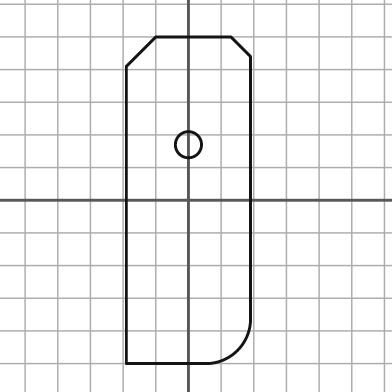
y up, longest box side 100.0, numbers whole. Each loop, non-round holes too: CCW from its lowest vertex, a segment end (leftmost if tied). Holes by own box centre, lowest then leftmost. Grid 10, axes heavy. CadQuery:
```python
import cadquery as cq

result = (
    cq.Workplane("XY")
    .moveTo(-19.0, -50.0)
    .lineTo(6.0, -50.0)
    .threePointArc((15.0, -46.0), (19.0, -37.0))
    .lineTo(19.0, 44.0)
    .lineTo(13.0, 50.0)
    .lineTo(-10.0, 50.0)
    .lineTo(-19.0, 41.0)
    .close()
    .moveTo(0.0, 17.0)
    .circle(4.0)
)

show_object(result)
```